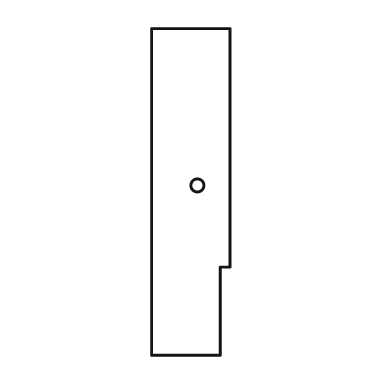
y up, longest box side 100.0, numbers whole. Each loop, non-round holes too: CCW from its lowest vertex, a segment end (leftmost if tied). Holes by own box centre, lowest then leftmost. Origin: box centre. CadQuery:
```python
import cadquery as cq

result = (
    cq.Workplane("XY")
    .moveTo(-12.0, -50.0)
    .lineTo(9.0, -50.0)
    .lineTo(9.0, -23.0)
    .lineTo(12.0, -23.0)
    .lineTo(12.0, 50.0)
    .lineTo(-12.0, 50.0)
    .close()
    .moveTo(2.0, 2.0)
    .circle(2.0)
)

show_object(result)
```